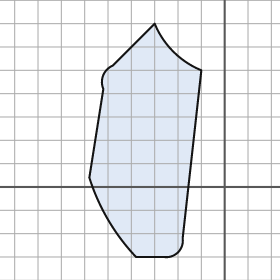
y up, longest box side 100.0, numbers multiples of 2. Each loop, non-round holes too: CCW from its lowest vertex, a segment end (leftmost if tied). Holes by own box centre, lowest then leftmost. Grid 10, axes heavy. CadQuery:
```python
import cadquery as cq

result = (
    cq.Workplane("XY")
    .moveTo(-38.0, -30.0)
    .lineTo(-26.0, -30.0)
    .threePointArc((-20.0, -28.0), (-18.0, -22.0))
    .lineTo(-10.0, 50.0)
    .threePointArc((-22.0, 58.0), (-30.0, 70.0))
    .lineTo(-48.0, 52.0)
    .threePointArc((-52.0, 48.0), (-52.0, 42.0))
    .lineTo(-58.0, 4.0)
    .threePointArc((-50.0, -14.0), (-38.0, -30.0))
    .close()
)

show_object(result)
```